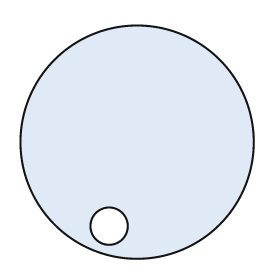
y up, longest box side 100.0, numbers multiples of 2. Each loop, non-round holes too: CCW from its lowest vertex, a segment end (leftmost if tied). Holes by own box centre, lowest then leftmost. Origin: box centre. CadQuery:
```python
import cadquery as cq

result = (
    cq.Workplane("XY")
    .moveTo(0.0, 0.0)
    .circle(50.0)
    .moveTo(-12.0, -36.0)
    .circle(8.0)
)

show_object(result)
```